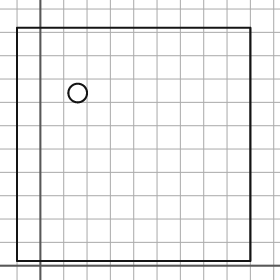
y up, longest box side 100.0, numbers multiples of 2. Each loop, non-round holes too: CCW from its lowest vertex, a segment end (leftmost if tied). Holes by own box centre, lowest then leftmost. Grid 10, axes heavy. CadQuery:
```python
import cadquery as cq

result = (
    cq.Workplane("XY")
    .moveTo(-10.0, 2.0)
    .lineTo(90.0, 2.0)
    .lineTo(90.0, 102.0)
    .lineTo(-10.0, 102.0)
    .close()
    .moveTo(16.0, 74.0)
    .circle(4.0)
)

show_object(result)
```